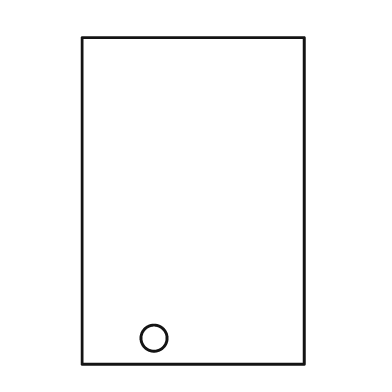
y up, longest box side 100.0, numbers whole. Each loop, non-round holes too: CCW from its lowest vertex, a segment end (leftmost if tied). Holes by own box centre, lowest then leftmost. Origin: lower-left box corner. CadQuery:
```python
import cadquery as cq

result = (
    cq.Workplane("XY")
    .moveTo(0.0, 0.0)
    .lineTo(68.0, 0.0)
    .lineTo(68.0, 100.0)
    .lineTo(0.0, 100.0)
    .close()
    .moveTo(22.0, 8.0)
    .circle(4.0)
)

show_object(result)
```